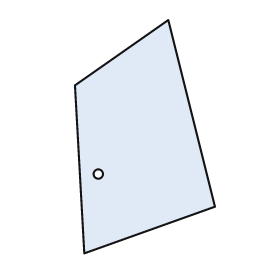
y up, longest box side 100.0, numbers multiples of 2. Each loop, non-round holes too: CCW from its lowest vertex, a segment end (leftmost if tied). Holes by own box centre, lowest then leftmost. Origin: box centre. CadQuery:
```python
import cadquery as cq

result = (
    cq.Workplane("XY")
    .moveTo(-26.0, -50.0)
    .lineTo(30.0, -30.0)
    .lineTo(10.0, 50.0)
    .lineTo(-30.0, 22.0)
    .close()
    .moveTo(-20.0, -16.0)
    .circle(2.0)
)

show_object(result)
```